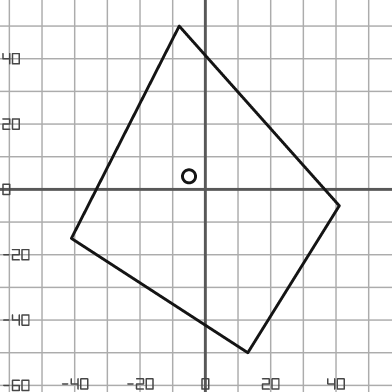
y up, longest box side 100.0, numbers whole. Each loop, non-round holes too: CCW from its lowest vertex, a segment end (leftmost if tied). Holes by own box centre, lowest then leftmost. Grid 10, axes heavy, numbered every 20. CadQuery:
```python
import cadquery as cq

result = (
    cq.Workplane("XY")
    .moveTo(13.0, -50.0)
    .lineTo(41.0, -5.0)
    .lineTo(-8.0, 50.0)
    .lineTo(-41.0, -15.0)
    .close()
    .moveTo(-5.0, 4.0)
    .circle(2.0)
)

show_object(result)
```